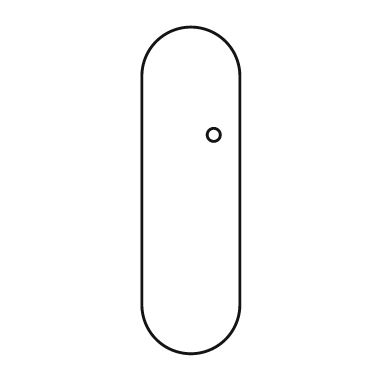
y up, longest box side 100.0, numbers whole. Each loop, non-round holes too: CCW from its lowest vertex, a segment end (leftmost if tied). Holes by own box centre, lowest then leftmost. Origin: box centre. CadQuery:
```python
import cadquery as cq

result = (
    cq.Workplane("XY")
    .moveTo(-15.0, -35.0)
    .threePointArc((0.0, -50.0), (15.0, -35.0))
    .lineTo(15.0, 35.0)
    .threePointArc((0.0, 50.0), (-15.0, 35.0))
    .close()
    .moveTo(7.0, 17.0)
    .circle(2.0)
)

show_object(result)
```